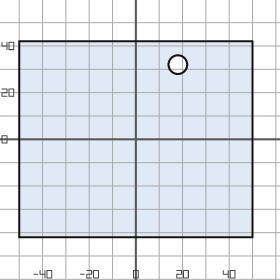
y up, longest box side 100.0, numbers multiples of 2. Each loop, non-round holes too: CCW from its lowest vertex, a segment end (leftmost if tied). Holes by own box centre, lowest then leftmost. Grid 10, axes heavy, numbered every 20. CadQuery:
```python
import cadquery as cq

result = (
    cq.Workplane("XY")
    .moveTo(-50.0, -42.0)
    .lineTo(50.0, -42.0)
    .lineTo(50.0, 42.0)
    .lineTo(-50.0, 42.0)
    .close()
    .moveTo(18.0, 32.0)
    .circle(4.0)
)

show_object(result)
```